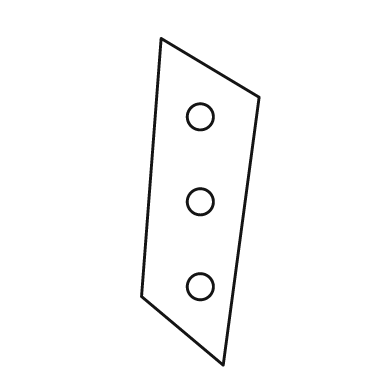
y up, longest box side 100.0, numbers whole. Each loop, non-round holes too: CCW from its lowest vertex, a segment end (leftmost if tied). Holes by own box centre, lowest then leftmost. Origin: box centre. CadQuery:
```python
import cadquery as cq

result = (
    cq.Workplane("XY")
    .moveTo(7.0, -50.0)
    .lineTo(18.0, 32.0)
    .lineTo(-12.0, 50.0)
    .lineTo(-18.0, -29.0)
    .close()
    .moveTo(0.0, -26.0)
    .circle(4.0)
    .moveTo(0.0, 0.0)
    .circle(4.0)
    .moveTo(0.0, 26.0)
    .circle(4.0)
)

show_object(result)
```